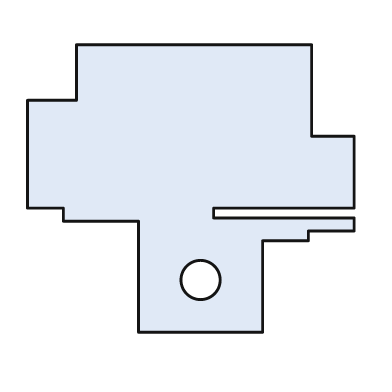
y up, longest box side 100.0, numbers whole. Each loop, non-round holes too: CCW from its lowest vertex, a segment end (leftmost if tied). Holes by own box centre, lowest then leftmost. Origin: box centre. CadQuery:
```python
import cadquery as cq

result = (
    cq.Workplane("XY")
    .moveTo(-16.0, -44.0)
    .lineTo(22.0, -44.0)
    .lineTo(22.0, -16.0)
    .lineTo(36.0, -16.0)
    .lineTo(36.0, -13.0)
    .lineTo(50.0, -13.0)
    .lineTo(50.0, -9.0)
    .lineTo(7.0, -9.0)
    .lineTo(7.0, -6.0)
    .lineTo(50.0, -6.0)
    .lineTo(50.0, 16.0)
    .lineTo(37.0, 16.0)
    .lineTo(37.0, 44.0)
    .lineTo(-35.0, 44.0)
    .lineTo(-35.0, 27.0)
    .lineTo(-50.0, 27.0)
    .lineTo(-50.0, -6.0)
    .lineTo(-39.0, -6.0)
    .lineTo(-39.0, -10.0)
    .lineTo(-16.0, -10.0)
    .close()
    .moveTo(3.0, -28.0)
    .circle(6.0)
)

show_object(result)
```